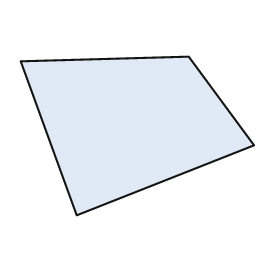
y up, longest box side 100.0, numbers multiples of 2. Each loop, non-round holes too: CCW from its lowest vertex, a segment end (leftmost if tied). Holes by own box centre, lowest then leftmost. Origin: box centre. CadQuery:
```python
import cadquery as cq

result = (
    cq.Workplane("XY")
    .moveTo(-26.0, -34.0)
    .lineTo(50.0, -4.0)
    .lineTo(22.0, 34.0)
    .lineTo(-50.0, 32.0)
    .close()
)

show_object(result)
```